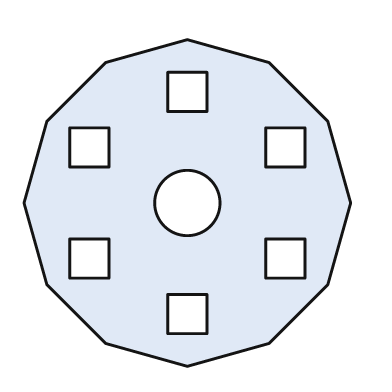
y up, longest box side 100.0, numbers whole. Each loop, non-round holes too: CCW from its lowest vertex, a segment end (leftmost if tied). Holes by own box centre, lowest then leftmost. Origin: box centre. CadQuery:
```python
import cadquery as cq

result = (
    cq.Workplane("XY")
    .moveTo(0.0, -50.0)
    .lineTo(25.0, -43.0)
    .lineTo(43.0, -25.0)
    .lineTo(50.0, 0.0)
    .lineTo(43.0, 25.0)
    .lineTo(25.0, 43.0)
    .lineTo(0.0, 50.0)
    .lineTo(-25.0, 43.0)
    .lineTo(-43.0, 25.0)
    .lineTo(-50.0, 0.0)
    .lineTo(-43.0, -25.0)
    .lineTo(-25.0, -43.0)
    .close()
    .moveTo(-6.0, -40.0)
    .lineTo(6.0, -40.0)
    .lineTo(6.0, -28.0)
    .lineTo(-6.0, -28.0)
    .close()
    .moveTo(-36.0, -23.0)
    .lineTo(-24.0, -23.0)
    .lineTo(-24.0, -11.0)
    .lineTo(-36.0, -11.0)
    .close()
    .moveTo(24.0, -23.0)
    .lineTo(36.0, -23.0)
    .lineTo(36.0, -11.0)
    .lineTo(24.0, -11.0)
    .close()
    .moveTo(0.0, 0.0)
    .circle(10.0)
    .moveTo(-36.0, 11.0)
    .lineTo(-24.0, 11.0)
    .lineTo(-24.0, 23.0)
    .lineTo(-36.0, 23.0)
    .close()
    .moveTo(24.0, 11.0)
    .lineTo(36.0, 11.0)
    .lineTo(36.0, 23.0)
    .lineTo(24.0, 23.0)
    .close()
    .moveTo(-6.0, 28.0)
    .lineTo(6.0, 28.0)
    .lineTo(6.0, 40.0)
    .lineTo(-6.0, 40.0)
    .close()
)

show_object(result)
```